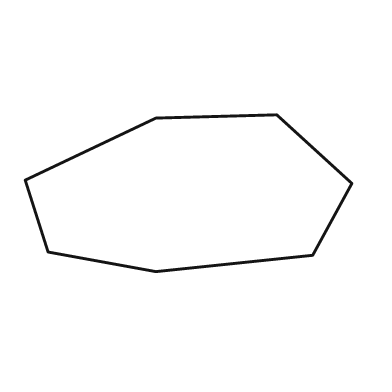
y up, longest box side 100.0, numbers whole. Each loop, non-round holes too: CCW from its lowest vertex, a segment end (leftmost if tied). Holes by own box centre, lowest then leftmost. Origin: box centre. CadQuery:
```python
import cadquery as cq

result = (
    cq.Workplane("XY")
    .moveTo(-10.0, -24.0)
    .lineTo(38.0, -19.0)
    .lineTo(50.0, 3.0)
    .lineTo(27.0, 24.0)
    .lineTo(-10.0, 23.0)
    .lineTo(-50.0, 4.0)
    .lineTo(-43.0, -18.0)
    .close()
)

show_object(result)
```